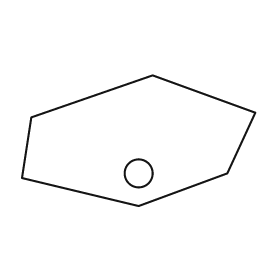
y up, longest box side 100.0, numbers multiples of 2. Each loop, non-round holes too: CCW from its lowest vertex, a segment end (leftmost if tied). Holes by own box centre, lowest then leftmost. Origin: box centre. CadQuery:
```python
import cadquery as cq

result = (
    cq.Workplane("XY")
    .moveTo(0.0, -28.0)
    .lineTo(38.0, -14.0)
    .lineTo(50.0, 12.0)
    .lineTo(6.0, 28.0)
    .lineTo(-46.0, 10.0)
    .lineTo(-50.0, -16.0)
    .close()
    .moveTo(0.0, -14.0)
    .circle(6.0)
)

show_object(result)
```